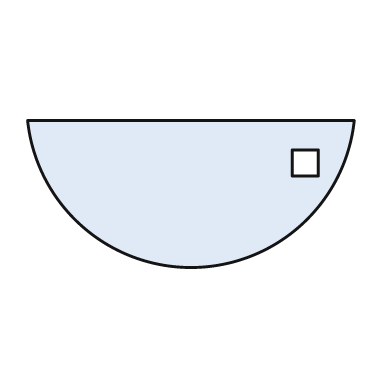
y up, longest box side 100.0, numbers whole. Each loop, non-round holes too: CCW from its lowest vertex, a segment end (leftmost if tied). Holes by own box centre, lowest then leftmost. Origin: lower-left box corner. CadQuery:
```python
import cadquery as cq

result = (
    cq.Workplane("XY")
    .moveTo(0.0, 45.0)
    .threePointArc((50.0, 0.0), (100.0, 45.0))
    .close()
    .moveTo(81.0, 28.0)
    .lineTo(89.0, 28.0)
    .lineTo(89.0, 36.0)
    .lineTo(81.0, 36.0)
    .close()
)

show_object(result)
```